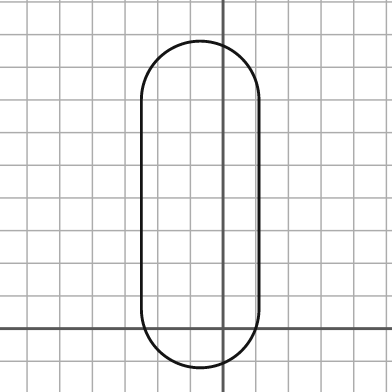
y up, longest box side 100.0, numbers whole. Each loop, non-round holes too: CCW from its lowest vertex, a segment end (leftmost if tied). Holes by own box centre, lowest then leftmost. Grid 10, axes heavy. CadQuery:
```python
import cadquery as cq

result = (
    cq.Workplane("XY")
    .moveTo(-25.0, 6.0)
    .threePointArc((-7.0, -12.0), (11.0, 6.0))
    .lineTo(11.0, 70.0)
    .threePointArc((-7.0, 88.0), (-25.0, 70.0))
    .close()
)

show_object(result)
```